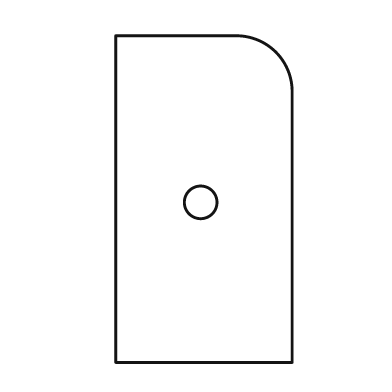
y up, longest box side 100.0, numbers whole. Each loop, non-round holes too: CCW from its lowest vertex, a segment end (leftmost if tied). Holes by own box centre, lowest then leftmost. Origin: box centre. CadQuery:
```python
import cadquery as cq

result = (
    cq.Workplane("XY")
    .moveTo(-27.0, -50.0)
    .lineTo(27.0, -50.0)
    .lineTo(27.0, 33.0)
    .threePointArc((22.0, 45.0), (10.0, 50.0))
    .lineTo(-27.0, 50.0)
    .close()
    .moveTo(-1.0, -1.0)
    .circle(5.0)
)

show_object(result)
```